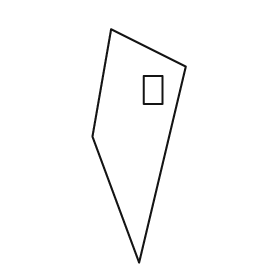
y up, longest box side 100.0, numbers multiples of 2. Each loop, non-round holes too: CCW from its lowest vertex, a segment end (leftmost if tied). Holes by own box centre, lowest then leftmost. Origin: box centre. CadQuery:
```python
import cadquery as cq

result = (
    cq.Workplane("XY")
    .moveTo(0.0, -50.0)
    .lineTo(20.0, 34.0)
    .lineTo(-12.0, 50.0)
    .lineTo(-20.0, 4.0)
    .close()
    .moveTo(2.0, 18.0)
    .lineTo(10.0, 18.0)
    .lineTo(10.0, 30.0)
    .lineTo(2.0, 30.0)
    .close()
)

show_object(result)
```